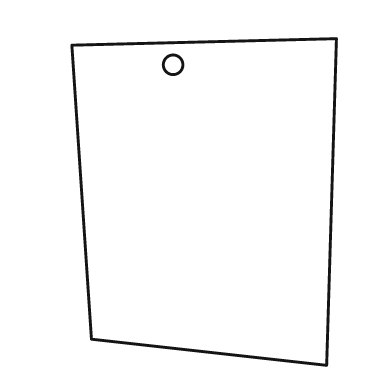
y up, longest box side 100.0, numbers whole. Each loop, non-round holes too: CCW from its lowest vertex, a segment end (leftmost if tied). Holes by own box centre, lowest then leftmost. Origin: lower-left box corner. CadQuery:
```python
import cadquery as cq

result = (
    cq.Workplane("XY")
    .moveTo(78.0, 0.0)
    .lineTo(81.0, 100.0)
    .lineTo(0.0, 98.0)
    .lineTo(6.0, 8.0)
    .close()
    .moveTo(31.0, 92.0)
    .circle(3.0)
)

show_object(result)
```